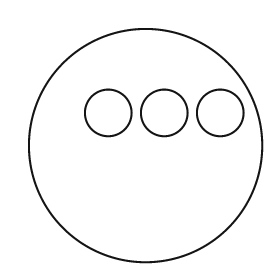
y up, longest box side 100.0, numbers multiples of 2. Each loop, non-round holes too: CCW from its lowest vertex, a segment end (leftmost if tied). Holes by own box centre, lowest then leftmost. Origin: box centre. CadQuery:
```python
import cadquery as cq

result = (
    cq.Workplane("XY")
    .moveTo(0.0, 0.0)
    .circle(50.0)
    .moveTo(-16.0, 14.0)
    .circle(10.0)
    .moveTo(8.0, 14.0)
    .circle(10.0)
    .moveTo(32.0, 14.0)
    .circle(10.0)
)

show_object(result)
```